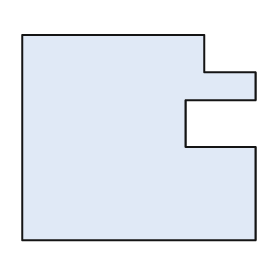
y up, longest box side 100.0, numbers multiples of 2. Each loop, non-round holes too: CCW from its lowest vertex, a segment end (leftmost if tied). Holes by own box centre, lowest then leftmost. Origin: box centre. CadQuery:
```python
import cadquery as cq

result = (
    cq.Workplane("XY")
    .moveTo(-50.0, -44.0)
    .lineTo(50.0, -44.0)
    .lineTo(50.0, -4.0)
    .lineTo(20.0, -4.0)
    .lineTo(20.0, 16.0)
    .lineTo(50.0, 16.0)
    .lineTo(50.0, 28.0)
    .lineTo(28.0, 28.0)
    .lineTo(28.0, 44.0)
    .lineTo(-50.0, 44.0)
    .close()
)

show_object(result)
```